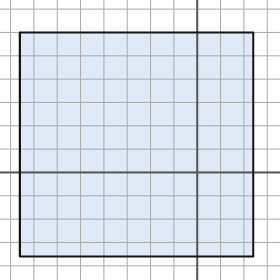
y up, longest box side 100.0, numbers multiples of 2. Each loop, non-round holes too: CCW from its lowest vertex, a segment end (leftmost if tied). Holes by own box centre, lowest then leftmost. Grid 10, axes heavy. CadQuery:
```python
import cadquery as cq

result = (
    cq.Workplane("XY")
    .moveTo(-76.0, -36.0)
    .lineTo(24.0, -36.0)
    .lineTo(24.0, 60.0)
    .lineTo(-76.0, 60.0)
    .close()
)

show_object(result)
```